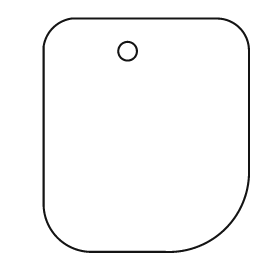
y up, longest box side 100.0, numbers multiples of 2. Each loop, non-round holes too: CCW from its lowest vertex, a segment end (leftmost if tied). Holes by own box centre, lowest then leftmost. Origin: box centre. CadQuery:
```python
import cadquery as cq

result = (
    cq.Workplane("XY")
    .moveTo(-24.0, -50.0)
    .lineTo(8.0, -50.0)
    .threePointArc((34.0, -40.0), (44.0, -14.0))
    .lineTo(44.0, 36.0)
    .threePointArc((40.0, 46.0), (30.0, 50.0))
    .lineTo(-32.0, 50.0)
    .threePointArc((-40.0, 46.0), (-44.0, 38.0))
    .lineTo(-44.0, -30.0)
    .threePointArc((-38.0, -44.0), (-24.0, -50.0))
    .close()
    .moveTo(-8.0, 36.0)
    .circle(4.0)
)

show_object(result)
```